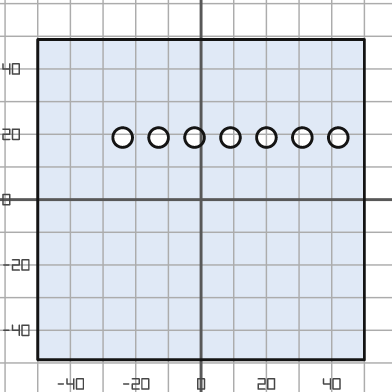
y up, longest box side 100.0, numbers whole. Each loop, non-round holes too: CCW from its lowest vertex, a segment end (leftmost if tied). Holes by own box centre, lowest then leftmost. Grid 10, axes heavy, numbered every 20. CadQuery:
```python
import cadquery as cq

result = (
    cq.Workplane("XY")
    .moveTo(-50.0, -49.0)
    .lineTo(50.0, -49.0)
    .lineTo(50.0, 49.0)
    .lineTo(-50.0, 49.0)
    .close()
    .moveTo(-24.0, 19.0)
    .circle(3.0)
    .moveTo(-13.0, 19.0)
    .circle(3.0)
    .moveTo(-2.0, 19.0)
    .circle(3.0)
    .moveTo(9.0, 19.0)
    .circle(3.0)
    .moveTo(20.0, 19.0)
    .circle(3.0)
    .moveTo(31.0, 19.0)
    .circle(3.0)
    .moveTo(42.0, 19.0)
    .circle(3.0)
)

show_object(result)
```